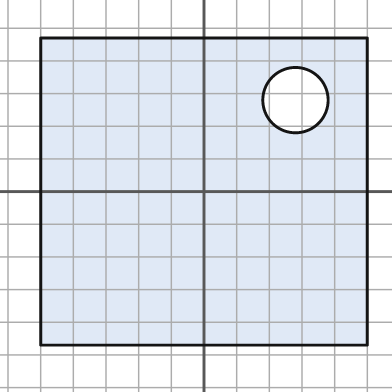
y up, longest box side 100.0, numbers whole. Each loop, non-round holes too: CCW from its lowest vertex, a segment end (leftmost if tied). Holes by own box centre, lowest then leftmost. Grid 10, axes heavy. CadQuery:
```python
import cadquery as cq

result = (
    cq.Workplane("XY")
    .moveTo(-50.0, -47.0)
    .lineTo(50.0, -47.0)
    .lineTo(50.0, 47.0)
    .lineTo(-50.0, 47.0)
    .close()
    .moveTo(28.0, 28.0)
    .circle(10.0)
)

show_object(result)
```